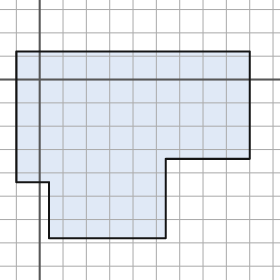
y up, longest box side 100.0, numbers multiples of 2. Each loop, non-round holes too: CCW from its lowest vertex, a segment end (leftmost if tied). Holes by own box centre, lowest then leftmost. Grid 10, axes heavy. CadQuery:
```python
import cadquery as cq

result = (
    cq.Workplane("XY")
    .moveTo(4.0, -68.0)
    .lineTo(54.0, -68.0)
    .lineTo(54.0, -34.0)
    .lineTo(90.0, -34.0)
    .lineTo(90.0, 12.0)
    .lineTo(-10.0, 12.0)
    .lineTo(-10.0, -44.0)
    .lineTo(4.0, -44.0)
    .close()
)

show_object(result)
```